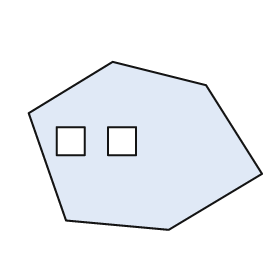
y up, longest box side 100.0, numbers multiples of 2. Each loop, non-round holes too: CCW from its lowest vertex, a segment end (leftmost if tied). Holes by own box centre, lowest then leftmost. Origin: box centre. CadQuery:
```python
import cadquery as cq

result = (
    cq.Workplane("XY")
    .moveTo(10.0, -36.0)
    .lineTo(50.0, -12.0)
    .lineTo(26.0, 26.0)
    .lineTo(-14.0, 36.0)
    .lineTo(-50.0, 14.0)
    .lineTo(-34.0, -32.0)
    .close()
    .moveTo(-38.0, -4.0)
    .lineTo(-26.0, -4.0)
    .lineTo(-26.0, 8.0)
    .lineTo(-38.0, 8.0)
    .close()
    .moveTo(-16.0, -4.0)
    .lineTo(-4.0, -4.0)
    .lineTo(-4.0, 8.0)
    .lineTo(-16.0, 8.0)
    .close()
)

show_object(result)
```